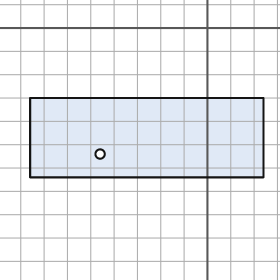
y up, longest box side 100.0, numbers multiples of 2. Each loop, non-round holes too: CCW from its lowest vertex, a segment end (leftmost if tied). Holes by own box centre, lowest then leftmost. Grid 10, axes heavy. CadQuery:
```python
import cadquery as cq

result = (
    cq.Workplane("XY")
    .moveTo(-76.0, -64.0)
    .lineTo(24.0, -64.0)
    .lineTo(24.0, -30.0)
    .lineTo(-76.0, -30.0)
    .close()
    .moveTo(-46.0, -54.0)
    .circle(2.0)
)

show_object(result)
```